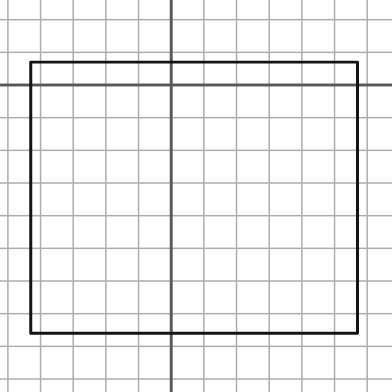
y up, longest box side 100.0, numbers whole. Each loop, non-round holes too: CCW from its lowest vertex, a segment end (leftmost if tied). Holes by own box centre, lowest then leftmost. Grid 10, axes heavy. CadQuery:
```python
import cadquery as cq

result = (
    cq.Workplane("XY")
    .moveTo(-43.0, -76.0)
    .lineTo(57.0, -76.0)
    .lineTo(57.0, 7.0)
    .lineTo(-43.0, 7.0)
    .close()
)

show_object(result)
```